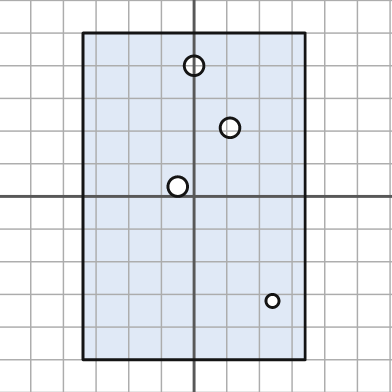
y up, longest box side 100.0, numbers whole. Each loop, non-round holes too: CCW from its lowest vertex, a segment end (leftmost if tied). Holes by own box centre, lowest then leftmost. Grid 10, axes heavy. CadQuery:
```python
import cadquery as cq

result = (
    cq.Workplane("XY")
    .moveTo(-34.0, -50.0)
    .lineTo(34.0, -50.0)
    .lineTo(34.0, 50.0)
    .lineTo(-34.0, 50.0)
    .close()
    .moveTo(24.0, -32.0)
    .circle(2.0)
    .moveTo(-5.0, 3.0)
    .circle(3.0)
    .moveTo(11.0, 21.0)
    .circle(3.0)
    .moveTo(0.0, 40.0)
    .circle(3.0)
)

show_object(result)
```